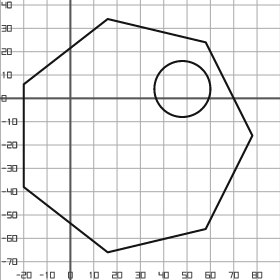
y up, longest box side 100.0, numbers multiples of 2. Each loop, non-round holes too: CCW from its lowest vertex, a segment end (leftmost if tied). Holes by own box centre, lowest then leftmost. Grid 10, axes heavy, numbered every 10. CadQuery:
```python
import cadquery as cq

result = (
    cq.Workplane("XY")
    .moveTo(16.0, -66.0)
    .lineTo(58.0, -56.0)
    .lineTo(78.0, -16.0)
    .lineTo(58.0, 24.0)
    .lineTo(16.0, 34.0)
    .lineTo(-20.0, 6.0)
    .lineTo(-20.0, -38.0)
    .close()
    .moveTo(48.0, 4.0)
    .circle(12.0)
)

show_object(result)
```